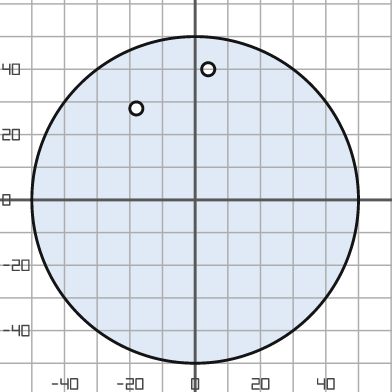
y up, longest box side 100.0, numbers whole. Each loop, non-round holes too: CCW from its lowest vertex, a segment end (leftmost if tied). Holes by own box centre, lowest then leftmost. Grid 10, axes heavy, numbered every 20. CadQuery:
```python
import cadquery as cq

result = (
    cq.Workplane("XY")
    .moveTo(0.0, 0.0)
    .circle(50.0)
    .moveTo(-18.0, 28.0)
    .circle(2.0)
    .moveTo(4.0, 40.0)
    .circle(2.0)
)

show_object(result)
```